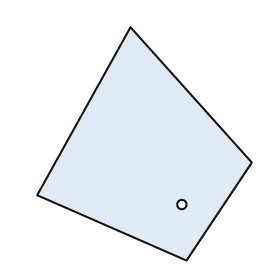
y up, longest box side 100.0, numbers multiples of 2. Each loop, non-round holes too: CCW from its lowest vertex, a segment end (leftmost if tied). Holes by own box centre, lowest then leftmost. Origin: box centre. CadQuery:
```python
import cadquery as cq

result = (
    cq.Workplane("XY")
    .moveTo(18.0, -50.0)
    .lineTo(46.0, -8.0)
    .lineTo(-6.0, 50.0)
    .lineTo(-46.0, -22.0)
    .close()
    .moveTo(16.0, -26.0)
    .circle(2.0)
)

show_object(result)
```